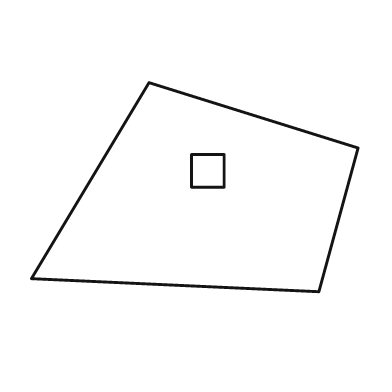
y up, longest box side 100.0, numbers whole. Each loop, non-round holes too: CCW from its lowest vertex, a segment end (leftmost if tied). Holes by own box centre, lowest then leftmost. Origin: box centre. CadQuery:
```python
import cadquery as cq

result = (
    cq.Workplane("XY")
    .moveTo(38.0, -32.0)
    .lineTo(50.0, 12.0)
    .lineTo(-14.0, 32.0)
    .lineTo(-50.0, -28.0)
    .close()
    .moveTo(-1.0, 0.0)
    .lineTo(9.0, 0.0)
    .lineTo(9.0, 10.0)
    .lineTo(-1.0, 10.0)
    .close()
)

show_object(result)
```